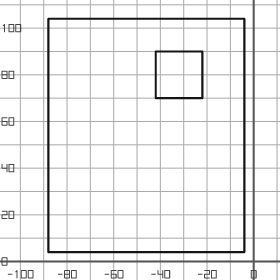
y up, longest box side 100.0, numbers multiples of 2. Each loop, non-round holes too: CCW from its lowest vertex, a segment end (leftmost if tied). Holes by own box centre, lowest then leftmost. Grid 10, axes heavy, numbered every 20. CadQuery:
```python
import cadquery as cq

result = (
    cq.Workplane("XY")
    .moveTo(-88.0, 4.0)
    .lineTo(-4.0, 4.0)
    .lineTo(-4.0, 104.0)
    .lineTo(-88.0, 104.0)
    .close()
    .moveTo(-42.0, 70.0)
    .lineTo(-22.0, 70.0)
    .lineTo(-22.0, 90.0)
    .lineTo(-42.0, 90.0)
    .close()
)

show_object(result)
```